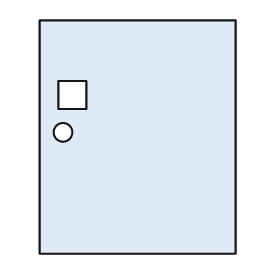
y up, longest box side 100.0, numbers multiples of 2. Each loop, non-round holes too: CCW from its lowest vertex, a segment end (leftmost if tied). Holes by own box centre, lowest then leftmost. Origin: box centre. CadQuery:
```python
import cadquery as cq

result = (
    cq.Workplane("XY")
    .moveTo(-42.0, -50.0)
    .lineTo(42.0, -50.0)
    .lineTo(42.0, 50.0)
    .lineTo(-42.0, 50.0)
    .close()
    .moveTo(-32.0, 2.0)
    .circle(4.0)
    .moveTo(-34.0, 12.0)
    .lineTo(-22.0, 12.0)
    .lineTo(-22.0, 24.0)
    .lineTo(-34.0, 24.0)
    .close()
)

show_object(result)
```